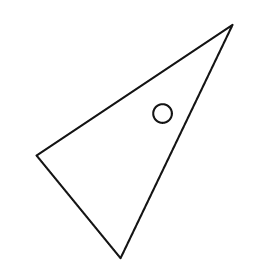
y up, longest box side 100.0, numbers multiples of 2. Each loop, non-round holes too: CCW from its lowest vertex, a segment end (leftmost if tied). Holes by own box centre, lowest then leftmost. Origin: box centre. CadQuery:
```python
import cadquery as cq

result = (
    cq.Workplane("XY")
    .moveTo(-6.0, -50.0)
    .lineTo(42.0, 50.0)
    .lineTo(-42.0, -6.0)
    .close()
    .moveTo(12.0, 12.0)
    .circle(4.0)
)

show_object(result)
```